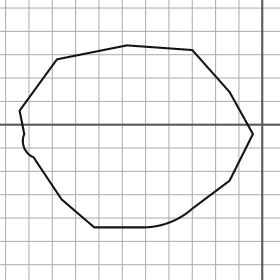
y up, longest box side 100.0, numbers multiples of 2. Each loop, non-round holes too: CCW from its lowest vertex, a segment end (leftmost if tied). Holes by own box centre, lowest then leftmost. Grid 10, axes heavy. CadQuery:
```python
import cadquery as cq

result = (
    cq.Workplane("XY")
    .moveTo(-72.0, -44.0)
    .lineTo(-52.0, -44.0)
    .threePointArc((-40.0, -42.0), (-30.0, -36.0))
    .lineTo(-14.0, -24.0)
    .lineTo(-4.0, -4.0)
    .lineTo(-14.0, 14.0)
    .lineTo(-30.0, 32.0)
    .lineTo(-58.0, 34.0)
    .lineTo(-88.0, 28.0)
    .lineTo(-104.0, 6.0)
    .lineTo(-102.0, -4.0)
    .threePointArc((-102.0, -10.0), (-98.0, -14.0))
    .lineTo(-86.0, -32.0)
    .close()
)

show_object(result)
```